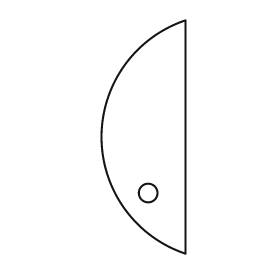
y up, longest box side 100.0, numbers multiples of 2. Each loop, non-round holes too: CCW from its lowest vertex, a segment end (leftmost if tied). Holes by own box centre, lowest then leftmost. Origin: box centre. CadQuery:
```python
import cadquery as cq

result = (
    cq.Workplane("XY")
    .moveTo(18.0, -50.0)
    .lineTo(18.0, 50.0)
    .threePointArc((-18.0, 0.0), (18.0, -50.0))
    .close()
    .moveTo(2.0, -24.0)
    .circle(4.0)
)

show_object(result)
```